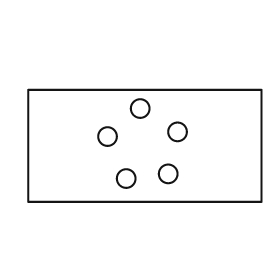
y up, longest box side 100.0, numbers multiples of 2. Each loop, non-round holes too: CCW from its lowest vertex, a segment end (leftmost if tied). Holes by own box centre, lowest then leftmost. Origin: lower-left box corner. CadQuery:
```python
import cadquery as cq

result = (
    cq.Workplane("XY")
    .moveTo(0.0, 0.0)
    .lineTo(100.0, 0.0)
    .lineTo(100.0, 48.0)
    .lineTo(0.0, 48.0)
    .close()
    .moveTo(42.0, 10.0)
    .circle(4.0)
    .moveTo(60.0, 12.0)
    .circle(4.0)
    .moveTo(34.0, 28.0)
    .circle(4.0)
    .moveTo(64.0, 30.0)
    .circle(4.0)
    .moveTo(48.0, 40.0)
    .circle(4.0)
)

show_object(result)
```